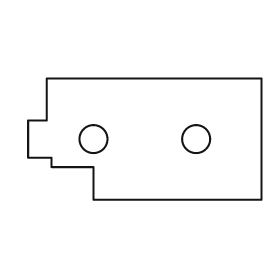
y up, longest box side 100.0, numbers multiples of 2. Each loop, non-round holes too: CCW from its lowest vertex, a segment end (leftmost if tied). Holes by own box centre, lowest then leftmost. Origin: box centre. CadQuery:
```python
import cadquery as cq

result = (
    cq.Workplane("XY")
    .moveTo(-22.0, -26.0)
    .lineTo(50.0, -26.0)
    .lineTo(50.0, 26.0)
    .lineTo(-42.0, 26.0)
    .lineTo(-42.0, 8.0)
    .lineTo(-50.0, 8.0)
    .lineTo(-50.0, -8.0)
    .lineTo(-40.0, -8.0)
    .lineTo(-40.0, -12.0)
    .lineTo(-22.0, -12.0)
    .close()
    .moveTo(-22.0, 0.0)
    .circle(6.0)
    .moveTo(22.0, 0.0)
    .circle(6.0)
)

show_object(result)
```